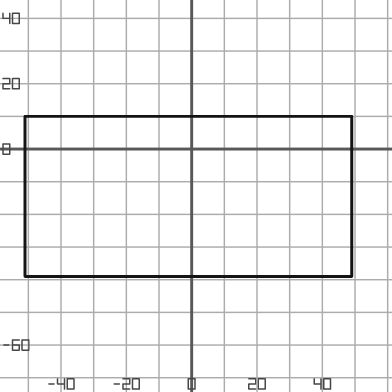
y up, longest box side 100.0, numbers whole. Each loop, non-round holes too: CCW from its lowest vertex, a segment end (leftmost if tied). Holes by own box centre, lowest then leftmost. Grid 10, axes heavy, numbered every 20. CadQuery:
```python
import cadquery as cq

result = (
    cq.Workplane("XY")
    .moveTo(-51.0, -39.0)
    .lineTo(49.0, -39.0)
    .lineTo(49.0, 10.0)
    .lineTo(-51.0, 10.0)
    .close()
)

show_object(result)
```